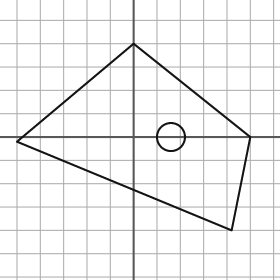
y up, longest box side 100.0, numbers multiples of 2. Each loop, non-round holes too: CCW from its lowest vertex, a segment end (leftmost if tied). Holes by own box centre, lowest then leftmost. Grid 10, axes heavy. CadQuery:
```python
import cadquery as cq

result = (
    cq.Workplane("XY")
    .moveTo(42.0, -40.0)
    .lineTo(50.0, 0.0)
    .lineTo(0.0, 40.0)
    .lineTo(-50.0, -2.0)
    .close()
    .moveTo(16.0, 0.0)
    .circle(6.0)
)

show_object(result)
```